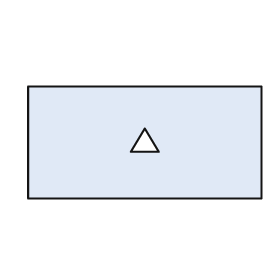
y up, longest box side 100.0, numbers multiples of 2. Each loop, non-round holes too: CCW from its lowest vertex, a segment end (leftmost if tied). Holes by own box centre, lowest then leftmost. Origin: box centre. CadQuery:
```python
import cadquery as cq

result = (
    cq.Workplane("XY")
    .moveTo(-50.0, -24.0)
    .lineTo(50.0, -24.0)
    .lineTo(50.0, 24.0)
    .lineTo(-50.0, 24.0)
    .close()
    .moveTo(-6.0, -4.0)
    .lineTo(6.0, -4.0)
    .lineTo(0.0, 6.0)
    .close()
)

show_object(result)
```